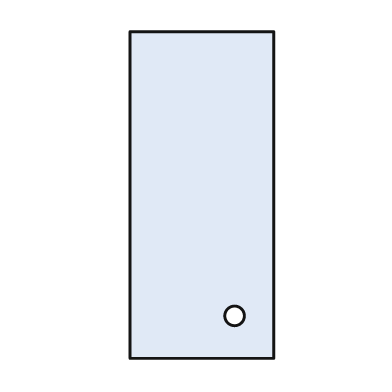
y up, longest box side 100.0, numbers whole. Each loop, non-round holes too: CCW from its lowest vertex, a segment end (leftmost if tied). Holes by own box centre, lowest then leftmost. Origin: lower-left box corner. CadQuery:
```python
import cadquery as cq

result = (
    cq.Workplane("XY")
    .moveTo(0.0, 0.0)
    .lineTo(44.0, 0.0)
    .lineTo(44.0, 100.0)
    .lineTo(0.0, 100.0)
    .close()
    .moveTo(32.0, 13.0)
    .circle(3.0)
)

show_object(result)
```